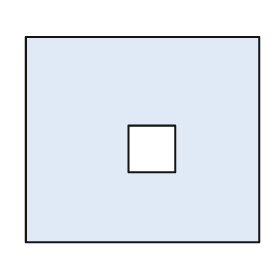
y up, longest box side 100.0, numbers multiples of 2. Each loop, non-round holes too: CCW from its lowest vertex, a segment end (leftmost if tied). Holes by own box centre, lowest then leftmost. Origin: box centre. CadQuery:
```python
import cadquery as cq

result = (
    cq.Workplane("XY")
    .moveTo(-50.0, -44.0)
    .lineTo(50.0, -44.0)
    .lineTo(50.0, 44.0)
    .lineTo(-50.0, 44.0)
    .close()
    .moveTo(-6.0, -14.0)
    .lineTo(14.0, -14.0)
    .lineTo(14.0, 6.0)
    .lineTo(-6.0, 6.0)
    .close()
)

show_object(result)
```